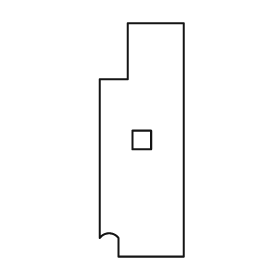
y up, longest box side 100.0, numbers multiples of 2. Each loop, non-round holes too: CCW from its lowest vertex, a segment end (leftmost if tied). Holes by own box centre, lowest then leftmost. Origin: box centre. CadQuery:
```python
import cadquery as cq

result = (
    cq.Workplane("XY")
    .moveTo(-10.0, -50.0)
    .lineTo(18.0, -50.0)
    .lineTo(18.0, 50.0)
    .lineTo(-6.0, 50.0)
    .lineTo(-6.0, 26.0)
    .lineTo(-18.0, 26.0)
    .lineTo(-18.0, -42.0)
    .threePointArc((-14.0, -40.0), (-10.0, -42.0))
    .close()
    .moveTo(-4.0, -4.0)
    .lineTo(4.0, -4.0)
    .lineTo(4.0, 4.0)
    .lineTo(-4.0, 4.0)
    .close()
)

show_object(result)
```